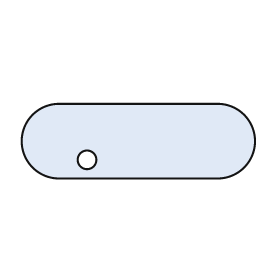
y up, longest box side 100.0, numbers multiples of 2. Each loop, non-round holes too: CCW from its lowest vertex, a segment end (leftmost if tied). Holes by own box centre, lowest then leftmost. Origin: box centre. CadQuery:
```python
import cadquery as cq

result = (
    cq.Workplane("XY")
    .moveTo(-34.0, -16.0)
    .lineTo(34.0, -16.0)
    .threePointArc((50.0, 0.0), (34.0, 16.0))
    .lineTo(-34.0, 16.0)
    .threePointArc((-50.0, 0.0), (-34.0, -16.0))
    .close()
    .moveTo(-22.0, -8.0)
    .circle(4.0)
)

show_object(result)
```